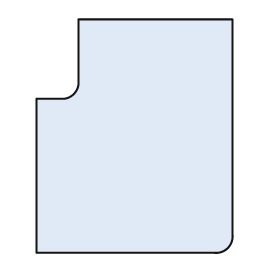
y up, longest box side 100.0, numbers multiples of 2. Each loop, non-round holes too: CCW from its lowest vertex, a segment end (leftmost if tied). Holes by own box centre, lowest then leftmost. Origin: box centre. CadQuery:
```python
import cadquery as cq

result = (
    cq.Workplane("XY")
    .moveTo(-42.0, -50.0)
    .lineTo(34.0, -50.0)
    .threePointArc((40.0, -48.0), (42.0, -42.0))
    .lineTo(42.0, 50.0)
    .lineTo(-24.0, 50.0)
    .lineTo(-24.0, 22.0)
    .threePointArc((-26.0, 18.0), (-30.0, 16.0))
    .lineTo(-42.0, 16.0)
    .close()
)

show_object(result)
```